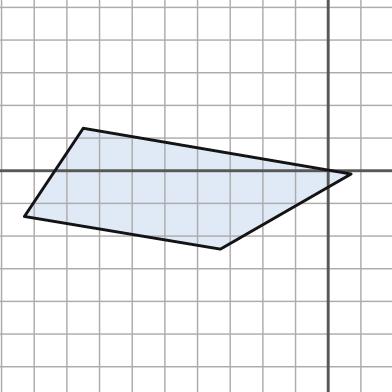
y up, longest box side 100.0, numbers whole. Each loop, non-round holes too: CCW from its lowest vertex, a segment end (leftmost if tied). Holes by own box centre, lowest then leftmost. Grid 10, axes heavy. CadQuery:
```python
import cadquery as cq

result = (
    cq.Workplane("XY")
    .moveTo(-33.0, -24.0)
    .lineTo(7.0, -1.0)
    .lineTo(-75.0, 13.0)
    .lineTo(-93.0, -14.0)
    .close()
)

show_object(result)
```